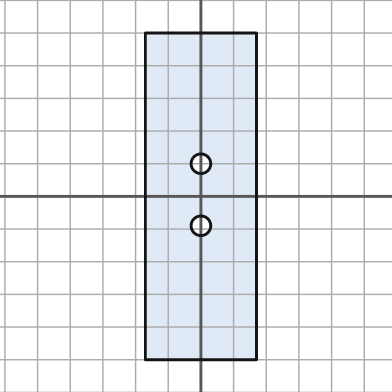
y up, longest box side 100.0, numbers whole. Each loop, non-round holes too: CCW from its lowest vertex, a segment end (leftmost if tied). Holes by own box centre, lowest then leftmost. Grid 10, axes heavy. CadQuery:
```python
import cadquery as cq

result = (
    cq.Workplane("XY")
    .moveTo(-17.0, -50.0)
    .lineTo(17.0, -50.0)
    .lineTo(17.0, 50.0)
    .lineTo(-17.0, 50.0)
    .close()
    .moveTo(0.0, -9.0)
    .circle(3.0)
    .moveTo(0.0, 10.0)
    .circle(3.0)
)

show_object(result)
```